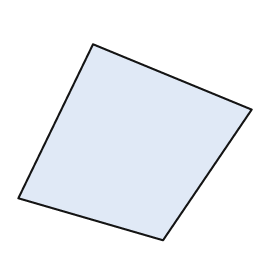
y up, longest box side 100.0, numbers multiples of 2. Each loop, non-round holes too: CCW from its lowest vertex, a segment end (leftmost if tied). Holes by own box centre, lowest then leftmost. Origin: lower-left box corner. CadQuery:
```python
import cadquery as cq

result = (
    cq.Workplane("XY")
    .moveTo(62.0, 0.0)
    .lineTo(100.0, 56.0)
    .lineTo(32.0, 84.0)
    .lineTo(0.0, 18.0)
    .close()
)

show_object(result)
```